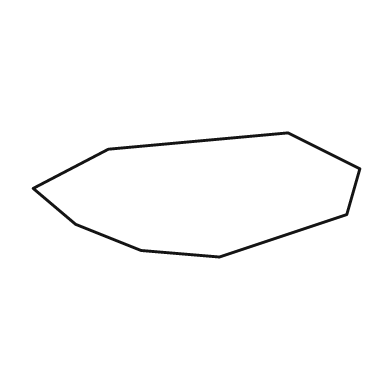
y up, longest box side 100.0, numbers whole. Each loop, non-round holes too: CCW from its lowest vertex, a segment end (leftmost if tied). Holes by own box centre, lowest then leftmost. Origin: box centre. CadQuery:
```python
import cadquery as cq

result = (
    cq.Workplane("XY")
    .moveTo(7.0, -19.0)
    .lineTo(46.0, -6.0)
    .lineTo(50.0, 8.0)
    .lineTo(28.0, 19.0)
    .lineTo(-27.0, 14.0)
    .lineTo(-50.0, 2.0)
    .lineTo(-37.0, -9.0)
    .lineTo(-17.0, -17.0)
    .close()
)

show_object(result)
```